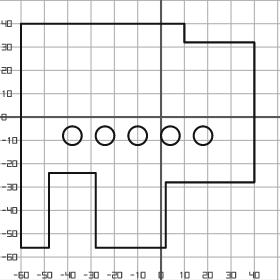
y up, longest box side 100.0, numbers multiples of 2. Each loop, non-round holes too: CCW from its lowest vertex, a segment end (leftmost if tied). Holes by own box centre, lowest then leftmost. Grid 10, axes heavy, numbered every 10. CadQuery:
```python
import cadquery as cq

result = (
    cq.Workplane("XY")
    .moveTo(-60.0, -56.0)
    .lineTo(-48.0, -56.0)
    .lineTo(-48.0, -24.0)
    .lineTo(-28.0, -24.0)
    .lineTo(-28.0, -56.0)
    .lineTo(2.0, -56.0)
    .lineTo(2.0, -28.0)
    .lineTo(40.0, -28.0)
    .lineTo(40.0, 32.0)
    .lineTo(10.0, 32.0)
    .lineTo(10.0, 40.0)
    .lineTo(-60.0, 40.0)
    .close()
    .moveTo(-38.0, -8.0)
    .circle(4.0)
    .moveTo(-24.0, -8.0)
    .circle(4.0)
    .moveTo(-10.0, -8.0)
    .circle(4.0)
    .moveTo(4.0, -8.0)
    .circle(4.0)
    .moveTo(18.0, -8.0)
    .circle(4.0)
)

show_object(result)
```